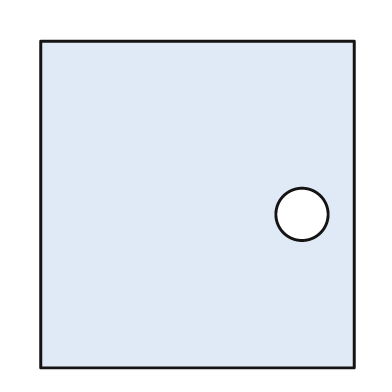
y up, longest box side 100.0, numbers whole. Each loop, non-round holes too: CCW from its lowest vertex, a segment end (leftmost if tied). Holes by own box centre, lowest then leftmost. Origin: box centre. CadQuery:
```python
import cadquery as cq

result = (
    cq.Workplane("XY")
    .moveTo(-48.0, -50.0)
    .lineTo(48.0, -50.0)
    .lineTo(48.0, 50.0)
    .lineTo(-48.0, 50.0)
    .close()
    .moveTo(32.0, -3.0)
    .circle(8.0)
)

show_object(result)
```